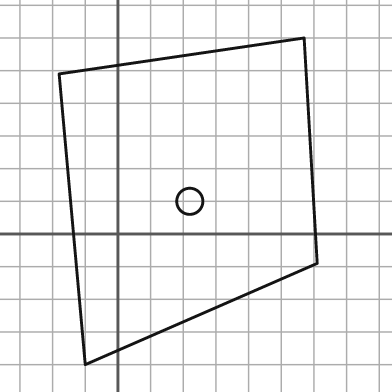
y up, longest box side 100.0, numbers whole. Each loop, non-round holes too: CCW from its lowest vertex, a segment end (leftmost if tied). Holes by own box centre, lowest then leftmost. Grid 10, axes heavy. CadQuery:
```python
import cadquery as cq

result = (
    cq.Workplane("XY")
    .moveTo(-10.0, -40.0)
    .lineTo(61.0, -9.0)
    .lineTo(57.0, 60.0)
    .lineTo(-18.0, 49.0)
    .close()
    .moveTo(22.0, 10.0)
    .circle(4.0)
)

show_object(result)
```